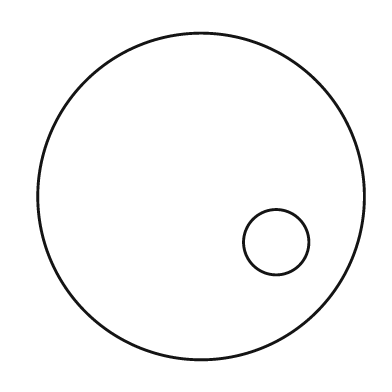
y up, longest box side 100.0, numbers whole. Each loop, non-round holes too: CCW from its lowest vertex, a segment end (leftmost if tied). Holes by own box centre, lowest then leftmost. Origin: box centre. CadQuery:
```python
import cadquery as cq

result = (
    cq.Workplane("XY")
    .moveTo(0.0, 0.0)
    .circle(50.0)
    .moveTo(23.0, -14.0)
    .circle(10.0)
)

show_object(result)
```